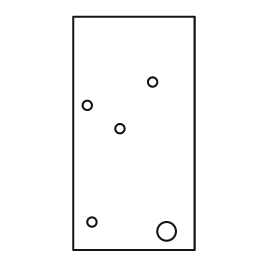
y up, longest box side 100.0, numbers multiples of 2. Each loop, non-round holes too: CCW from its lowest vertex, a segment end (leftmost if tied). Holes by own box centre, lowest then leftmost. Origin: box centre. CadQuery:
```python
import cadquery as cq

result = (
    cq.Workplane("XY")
    .moveTo(-26.0, -50.0)
    .lineTo(26.0, -50.0)
    .lineTo(26.0, 50.0)
    .lineTo(-26.0, 50.0)
    .close()
    .moveTo(14.0, -42.0)
    .circle(4.0)
    .moveTo(-18.0, -38.0)
    .circle(2.0)
    .moveTo(-6.0, 2.0)
    .circle(2.0)
    .moveTo(-20.0, 12.0)
    .circle(2.0)
    .moveTo(8.0, 22.0)
    .circle(2.0)
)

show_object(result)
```